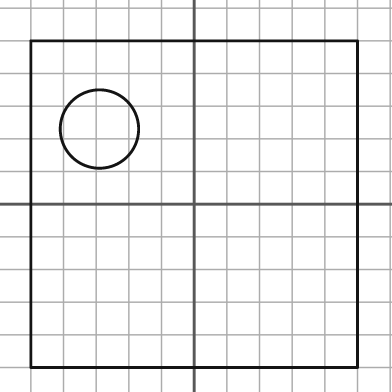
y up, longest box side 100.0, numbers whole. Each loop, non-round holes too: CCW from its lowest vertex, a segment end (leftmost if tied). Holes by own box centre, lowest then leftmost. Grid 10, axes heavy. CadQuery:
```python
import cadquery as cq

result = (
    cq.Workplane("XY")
    .moveTo(-50.0, -50.0)
    .lineTo(50.0, -50.0)
    .lineTo(50.0, 50.0)
    .lineTo(-50.0, 50.0)
    .close()
    .moveTo(-29.0, 23.0)
    .circle(12.0)
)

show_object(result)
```